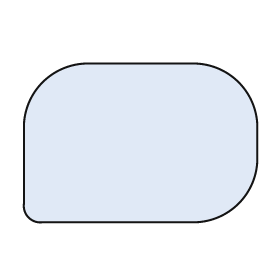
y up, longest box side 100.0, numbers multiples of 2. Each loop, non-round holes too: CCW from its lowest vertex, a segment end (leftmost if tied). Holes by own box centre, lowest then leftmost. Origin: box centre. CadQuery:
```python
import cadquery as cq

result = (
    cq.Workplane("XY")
    .moveTo(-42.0, -34.0)
    .lineTo(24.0, -34.0)
    .threePointArc((42.0, -26.0), (50.0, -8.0))
    .lineTo(50.0, 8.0)
    .threePointArc((42.0, 26.0), (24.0, 34.0))
    .lineTo(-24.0, 34.0)
    .threePointArc((-42.0, 26.0), (-50.0, 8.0))
    .lineTo(-50.0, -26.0)
    .threePointArc((-48.0, -32.0), (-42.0, -34.0))
    .close()
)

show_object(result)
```